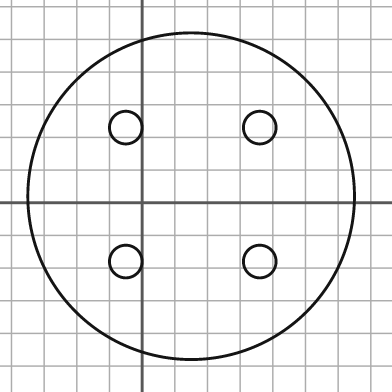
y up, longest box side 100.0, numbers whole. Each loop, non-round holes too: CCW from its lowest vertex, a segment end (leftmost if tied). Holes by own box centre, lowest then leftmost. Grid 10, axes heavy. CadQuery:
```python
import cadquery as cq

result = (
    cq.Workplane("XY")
    .moveTo(15.0, 2.0)
    .circle(50.0)
    .moveTo(-5.0, -18.0)
    .circle(5.0)
    .moveTo(36.0, -18.0)
    .circle(5.0)
    .moveTo(-5.0, 23.0)
    .circle(5.0)
    .moveTo(36.0, 23.0)
    .circle(5.0)
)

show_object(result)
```